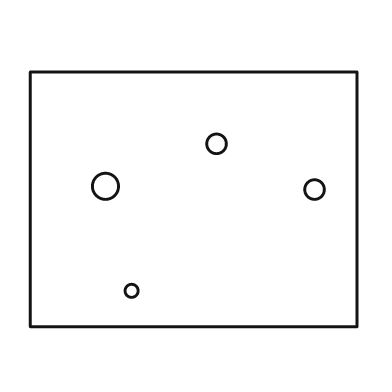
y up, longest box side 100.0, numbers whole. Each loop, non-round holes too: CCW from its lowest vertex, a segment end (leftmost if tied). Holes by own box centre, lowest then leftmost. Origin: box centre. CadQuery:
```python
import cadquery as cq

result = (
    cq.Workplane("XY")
    .moveTo(-50.0, -39.0)
    .lineTo(50.0, -39.0)
    .lineTo(50.0, 39.0)
    .lineTo(-50.0, 39.0)
    .close()
    .moveTo(-19.0, -28.0)
    .circle(2.0)
    .moveTo(37.0, 3.0)
    .circle(3.0)
    .moveTo(-27.0, 4.0)
    .circle(4.0)
    .moveTo(7.0, 17.0)
    .circle(3.0)
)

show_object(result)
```